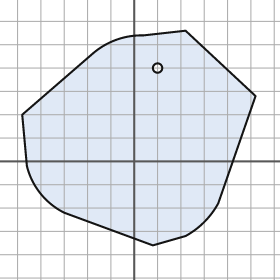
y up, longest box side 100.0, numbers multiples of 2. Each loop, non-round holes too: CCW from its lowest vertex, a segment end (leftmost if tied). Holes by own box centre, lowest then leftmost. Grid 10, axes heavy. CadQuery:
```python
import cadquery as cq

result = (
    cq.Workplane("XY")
    .moveTo(8.0, -36.0)
    .lineTo(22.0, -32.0)
    .threePointArc((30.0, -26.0), (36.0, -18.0))
    .lineTo(52.0, 28.0)
    .lineTo(22.0, 56.0)
    .lineTo(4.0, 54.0)
    .threePointArc((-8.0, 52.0), (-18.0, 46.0))
    .lineTo(-48.0, 20.0)
    .lineTo(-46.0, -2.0)
    .threePointArc((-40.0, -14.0), (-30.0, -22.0))
    .close()
    .moveTo(10.0, 40.0)
    .circle(2.0)
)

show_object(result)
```